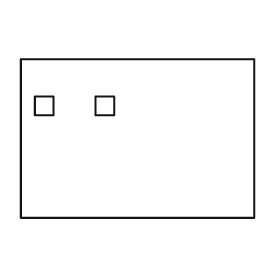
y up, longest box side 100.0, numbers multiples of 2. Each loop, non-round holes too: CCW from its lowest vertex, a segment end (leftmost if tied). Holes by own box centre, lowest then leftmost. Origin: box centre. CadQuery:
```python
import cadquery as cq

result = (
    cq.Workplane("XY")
    .moveTo(-50.0, -34.0)
    .lineTo(50.0, -34.0)
    .lineTo(50.0, 34.0)
    .lineTo(-50.0, 34.0)
    .close()
    .moveTo(-44.0, 10.0)
    .lineTo(-36.0, 10.0)
    .lineTo(-36.0, 18.0)
    .lineTo(-44.0, 18.0)
    .close()
    .moveTo(-18.0, 10.0)
    .lineTo(-10.0, 10.0)
    .lineTo(-10.0, 18.0)
    .lineTo(-18.0, 18.0)
    .close()
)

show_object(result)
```